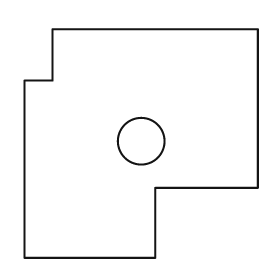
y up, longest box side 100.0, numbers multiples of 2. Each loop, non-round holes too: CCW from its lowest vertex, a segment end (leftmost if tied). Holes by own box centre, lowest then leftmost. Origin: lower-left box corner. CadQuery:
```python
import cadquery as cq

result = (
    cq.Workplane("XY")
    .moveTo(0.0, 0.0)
    .lineTo(56.0, 0.0)
    .lineTo(56.0, 30.0)
    .lineTo(100.0, 30.0)
    .lineTo(100.0, 98.0)
    .lineTo(12.0, 98.0)
    .lineTo(12.0, 76.0)
    .lineTo(0.0, 76.0)
    .close()
    .moveTo(50.0, 50.0)
    .circle(10.0)
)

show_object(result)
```